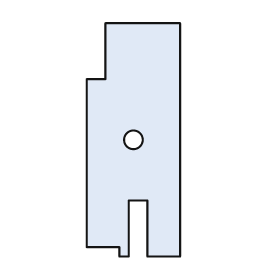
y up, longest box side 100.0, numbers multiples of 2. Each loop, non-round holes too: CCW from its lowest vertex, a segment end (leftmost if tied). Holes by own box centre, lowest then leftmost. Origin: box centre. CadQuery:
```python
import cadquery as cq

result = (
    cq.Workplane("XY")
    .moveTo(-6.0, -50.0)
    .lineTo(-2.0, -50.0)
    .lineTo(-2.0, -26.0)
    .lineTo(6.0, -26.0)
    .lineTo(6.0, -50.0)
    .lineTo(20.0, -50.0)
    .lineTo(20.0, 50.0)
    .lineTo(-12.0, 50.0)
    .lineTo(-12.0, 26.0)
    .lineTo(-20.0, 26.0)
    .lineTo(-20.0, -46.0)
    .lineTo(-6.0, -46.0)
    .close()
    .moveTo(0.0, 0.0)
    .circle(4.0)
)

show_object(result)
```